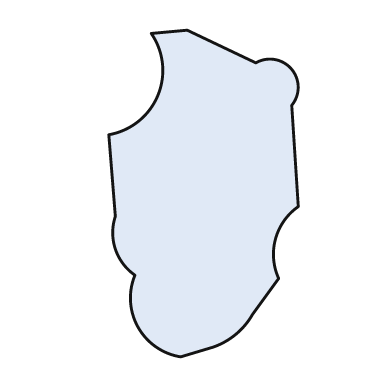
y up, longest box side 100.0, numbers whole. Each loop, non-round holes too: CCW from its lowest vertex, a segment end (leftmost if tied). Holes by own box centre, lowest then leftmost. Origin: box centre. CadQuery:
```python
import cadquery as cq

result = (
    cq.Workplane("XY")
    .moveTo(-7.0, -50.0)
    .lineTo(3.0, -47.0)
    .threePointArc((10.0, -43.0), (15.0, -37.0))
    .lineTo(23.0, -26.0)
    .threePointArc((22.0, -14.0), (29.0, -4.0))
    .lineTo(27.0, 27.0)
    .threePointArc((27.0, 38.0), (16.0, 40.0))
    .lineTo(-5.0, 50.0)
    .lineTo(-16.0, 49.0)
    .threePointArc((-14.0, 30.0), (-29.0, 18.0))
    .lineTo(-27.0, -7.0)
    .threePointArc((-27.0, -17.0), (-21.0, -25.0))
    .threePointArc((-20.0, -41.0), (-7.0, -50.0))
    .close()
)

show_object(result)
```